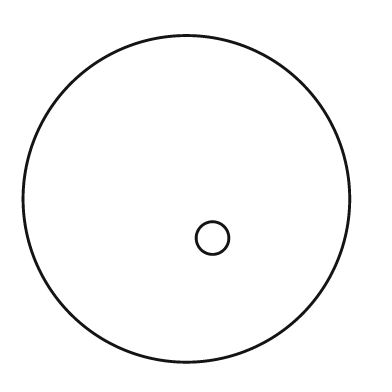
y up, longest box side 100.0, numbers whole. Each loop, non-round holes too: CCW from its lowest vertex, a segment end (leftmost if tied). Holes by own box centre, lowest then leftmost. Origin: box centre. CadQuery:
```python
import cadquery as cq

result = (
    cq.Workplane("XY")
    .moveTo(0.0, 0.0)
    .circle(50.0)
    .moveTo(8.0, -12.0)
    .circle(5.0)
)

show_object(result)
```